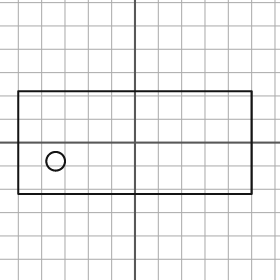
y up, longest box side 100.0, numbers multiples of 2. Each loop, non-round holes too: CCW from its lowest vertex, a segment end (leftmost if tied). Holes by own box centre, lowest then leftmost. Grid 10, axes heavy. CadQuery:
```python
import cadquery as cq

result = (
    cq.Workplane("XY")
    .moveTo(-50.0, -22.0)
    .lineTo(50.0, -22.0)
    .lineTo(50.0, 22.0)
    .lineTo(-50.0, 22.0)
    .close()
    .moveTo(-34.0, -8.0)
    .circle(4.0)
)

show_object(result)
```